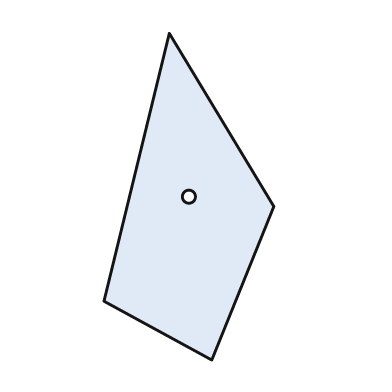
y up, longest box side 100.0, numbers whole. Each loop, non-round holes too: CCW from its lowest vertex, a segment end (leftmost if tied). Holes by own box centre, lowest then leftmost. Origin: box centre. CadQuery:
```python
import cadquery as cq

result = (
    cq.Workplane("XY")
    .moveTo(7.0, -50.0)
    .lineTo(26.0, -3.0)
    .lineTo(-6.0, 50.0)
    .lineTo(-26.0, -32.0)
    .close()
    .moveTo(0.0, 0.0)
    .circle(2.0)
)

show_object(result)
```